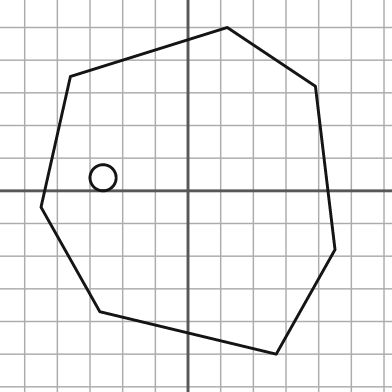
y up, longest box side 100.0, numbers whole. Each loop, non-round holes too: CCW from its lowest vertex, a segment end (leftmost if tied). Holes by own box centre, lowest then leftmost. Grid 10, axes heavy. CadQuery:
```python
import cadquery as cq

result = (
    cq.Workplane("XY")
    .moveTo(27.0, -50.0)
    .lineTo(45.0, -18.0)
    .lineTo(39.0, 32.0)
    .lineTo(12.0, 50.0)
    .lineTo(-36.0, 35.0)
    .lineTo(-45.0, -5.0)
    .lineTo(-27.0, -37.0)
    .close()
    .moveTo(-26.0, 4.0)
    .circle(4.0)
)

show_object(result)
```